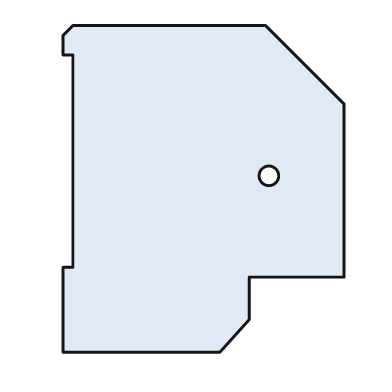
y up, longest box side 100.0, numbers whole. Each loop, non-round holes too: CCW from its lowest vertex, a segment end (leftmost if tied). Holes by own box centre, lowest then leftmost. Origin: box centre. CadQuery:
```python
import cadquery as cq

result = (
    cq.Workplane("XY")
    .moveTo(-43.0, -50.0)
    .lineTo(5.0, -50.0)
    .lineTo(14.0, -40.0)
    .lineTo(14.0, -27.0)
    .lineTo(43.0, -27.0)
    .lineTo(43.0, 26.0)
    .lineTo(19.0, 50.0)
    .lineTo(-40.0, 50.0)
    .lineTo(-43.0, 47.0)
    .lineTo(-43.0, 41.0)
    .lineTo(-40.0, 41.0)
    .lineTo(-40.0, -24.0)
    .lineTo(-43.0, -24.0)
    .close()
    .moveTo(20.0, 4.0)
    .circle(3.0)
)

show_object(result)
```